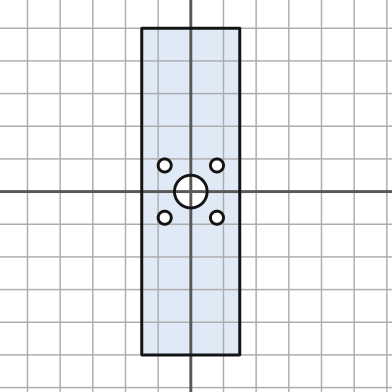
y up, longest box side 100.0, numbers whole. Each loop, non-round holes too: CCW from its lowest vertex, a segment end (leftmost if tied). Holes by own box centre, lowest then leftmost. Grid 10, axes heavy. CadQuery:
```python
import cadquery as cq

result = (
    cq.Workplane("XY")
    .moveTo(-15.0, -50.0)
    .lineTo(15.0, -50.0)
    .lineTo(15.0, 50.0)
    .lineTo(-15.0, 50.0)
    .close()
    .moveTo(-8.0, -8.0)
    .circle(2.0)
    .moveTo(8.0, -8.0)
    .circle(2.0)
    .moveTo(0.0, 0.0)
    .circle(5.0)
    .moveTo(-8.0, 8.0)
    .circle(2.0)
    .moveTo(8.0, 8.0)
    .circle(2.0)
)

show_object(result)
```